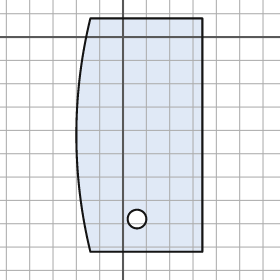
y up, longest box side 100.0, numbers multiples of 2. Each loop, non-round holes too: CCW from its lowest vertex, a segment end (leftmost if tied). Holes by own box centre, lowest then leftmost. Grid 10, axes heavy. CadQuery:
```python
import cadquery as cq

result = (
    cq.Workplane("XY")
    .moveTo(-14.0, -92.0)
    .lineTo(34.0, -92.0)
    .lineTo(34.0, 8.0)
    .lineTo(-14.0, 8.0)
    .threePointArc((-20.0, -42.0), (-14.0, -92.0))
    .close()
    .moveTo(6.0, -78.0)
    .circle(4.0)
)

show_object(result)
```